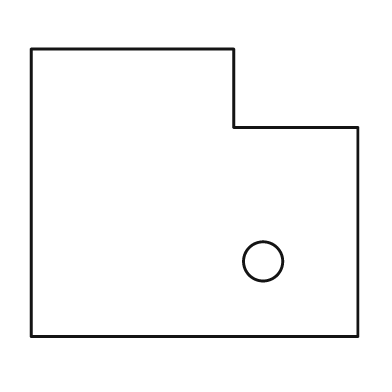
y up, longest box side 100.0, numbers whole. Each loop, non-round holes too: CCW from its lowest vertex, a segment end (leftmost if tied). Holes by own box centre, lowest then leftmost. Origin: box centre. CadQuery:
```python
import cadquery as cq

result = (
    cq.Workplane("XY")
    .moveTo(-50.0, -44.0)
    .lineTo(50.0, -44.0)
    .lineTo(50.0, 20.0)
    .lineTo(12.0, 20.0)
    .lineTo(12.0, 44.0)
    .lineTo(-50.0, 44.0)
    .close()
    .moveTo(21.0, -21.0)
    .circle(6.0)
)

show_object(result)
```